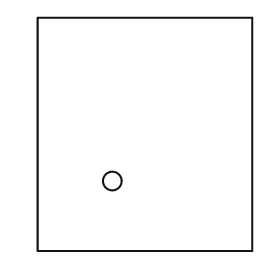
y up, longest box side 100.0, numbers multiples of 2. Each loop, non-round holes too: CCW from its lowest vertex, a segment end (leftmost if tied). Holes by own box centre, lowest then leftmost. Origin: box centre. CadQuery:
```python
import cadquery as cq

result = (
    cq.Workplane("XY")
    .moveTo(-46.0, -50.0)
    .lineTo(46.0, -50.0)
    .lineTo(46.0, 50.0)
    .lineTo(-46.0, 50.0)
    .close()
    .moveTo(-14.0, -20.0)
    .circle(4.0)
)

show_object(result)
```